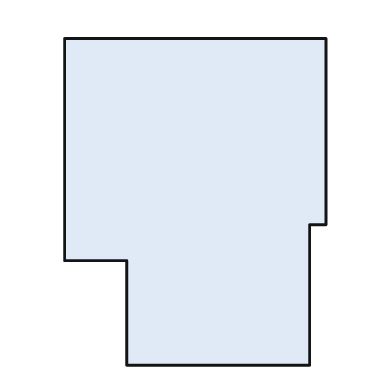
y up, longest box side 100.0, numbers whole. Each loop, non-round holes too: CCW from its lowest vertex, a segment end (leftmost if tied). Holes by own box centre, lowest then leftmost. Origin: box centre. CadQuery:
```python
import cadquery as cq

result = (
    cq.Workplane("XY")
    .moveTo(-21.0, -50.0)
    .lineTo(35.0, -50.0)
    .lineTo(35.0, -7.0)
    .lineTo(40.0, -7.0)
    .lineTo(40.0, 50.0)
    .lineTo(-40.0, 50.0)
    .lineTo(-40.0, -18.0)
    .lineTo(-21.0, -18.0)
    .close()
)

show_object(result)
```